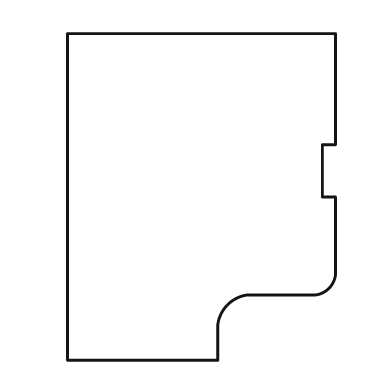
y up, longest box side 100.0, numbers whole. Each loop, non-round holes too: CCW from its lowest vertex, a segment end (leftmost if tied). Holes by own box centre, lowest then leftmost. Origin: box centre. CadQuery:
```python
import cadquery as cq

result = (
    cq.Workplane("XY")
    .moveTo(-41.0, -50.0)
    .lineTo(5.0, -50.0)
    .lineTo(5.0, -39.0)
    .threePointArc((8.0, -33.0), (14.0, -30.0))
    .lineTo(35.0, -30.0)
    .threePointArc((39.0, -28.0), (41.0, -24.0))
    .lineTo(41.0, 0.0)
    .lineTo(37.0, 0.0)
    .lineTo(37.0, 16.0)
    .lineTo(41.0, 16.0)
    .lineTo(41.0, 50.0)
    .lineTo(-41.0, 50.0)
    .close()
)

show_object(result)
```